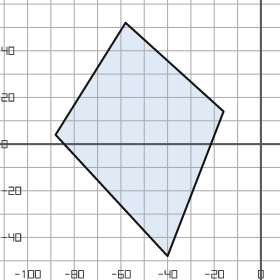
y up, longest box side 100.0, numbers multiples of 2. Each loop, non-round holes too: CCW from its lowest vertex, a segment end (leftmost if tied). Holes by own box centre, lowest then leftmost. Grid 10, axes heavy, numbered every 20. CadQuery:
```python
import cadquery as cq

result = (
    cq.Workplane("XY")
    .moveTo(-40.0, -48.0)
    .lineTo(-16.0, 14.0)
    .lineTo(-58.0, 52.0)
    .lineTo(-88.0, 4.0)
    .close()
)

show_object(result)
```